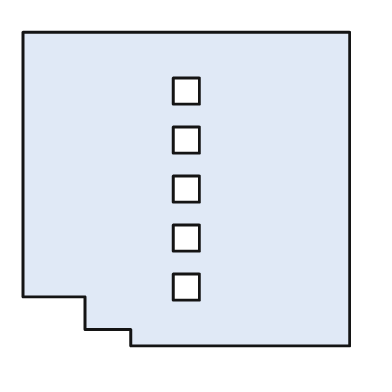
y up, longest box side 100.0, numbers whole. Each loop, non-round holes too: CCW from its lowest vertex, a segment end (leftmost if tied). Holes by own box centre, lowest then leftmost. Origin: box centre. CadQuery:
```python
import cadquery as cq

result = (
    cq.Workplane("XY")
    .moveTo(-17.0, -48.0)
    .lineTo(50.0, -48.0)
    .lineTo(50.0, 48.0)
    .lineTo(-50.0, 48.0)
    .lineTo(-50.0, -33.0)
    .lineTo(-31.0, -33.0)
    .lineTo(-31.0, -43.0)
    .lineTo(-17.0, -43.0)
    .close()
    .moveTo(-4.0, -34.0)
    .lineTo(4.0, -34.0)
    .lineTo(4.0, -26.0)
    .lineTo(-4.0, -26.0)
    .close()
    .moveTo(-4.0, -19.0)
    .lineTo(4.0, -19.0)
    .lineTo(4.0, -11.0)
    .lineTo(-4.0, -11.0)
    .close()
    .moveTo(-4.0, -4.0)
    .lineTo(4.0, -4.0)
    .lineTo(4.0, 4.0)
    .lineTo(-4.0, 4.0)
    .close()
    .moveTo(-4.0, 11.0)
    .lineTo(4.0, 11.0)
    .lineTo(4.0, 19.0)
    .lineTo(-4.0, 19.0)
    .close()
    .moveTo(-4.0, 26.0)
    .lineTo(4.0, 26.0)
    .lineTo(4.0, 34.0)
    .lineTo(-4.0, 34.0)
    .close()
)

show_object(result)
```